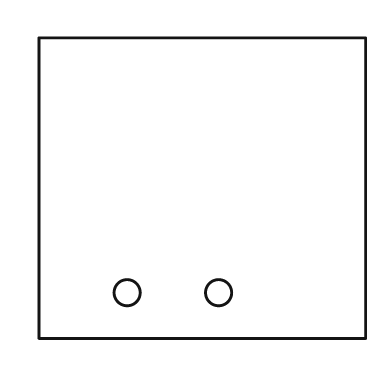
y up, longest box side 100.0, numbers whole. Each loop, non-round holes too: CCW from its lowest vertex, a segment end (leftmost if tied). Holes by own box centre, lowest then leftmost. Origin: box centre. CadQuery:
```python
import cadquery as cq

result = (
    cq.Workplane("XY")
    .moveTo(-50.0, -46.0)
    .lineTo(50.0, -46.0)
    .lineTo(50.0, 46.0)
    .lineTo(-50.0, 46.0)
    .close()
    .moveTo(-23.0, -32.0)
    .circle(4.0)
    .moveTo(5.0, -32.0)
    .circle(4.0)
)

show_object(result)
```